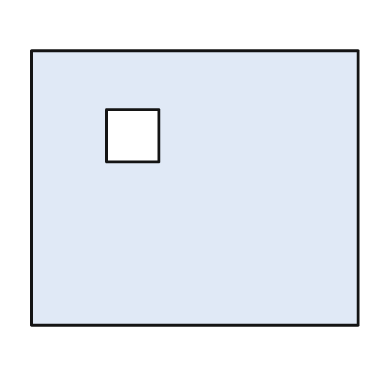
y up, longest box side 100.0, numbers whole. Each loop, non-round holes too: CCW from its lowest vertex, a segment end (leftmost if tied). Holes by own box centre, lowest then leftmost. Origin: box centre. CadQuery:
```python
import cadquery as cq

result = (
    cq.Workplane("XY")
    .moveTo(-50.0, -42.0)
    .lineTo(50.0, -42.0)
    .lineTo(50.0, 42.0)
    .lineTo(-50.0, 42.0)
    .close()
    .moveTo(-27.0, 8.0)
    .lineTo(-11.0, 8.0)
    .lineTo(-11.0, 24.0)
    .lineTo(-27.0, 24.0)
    .close()
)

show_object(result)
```